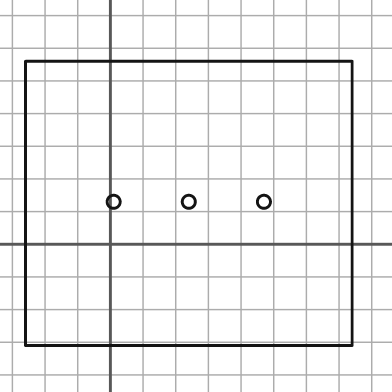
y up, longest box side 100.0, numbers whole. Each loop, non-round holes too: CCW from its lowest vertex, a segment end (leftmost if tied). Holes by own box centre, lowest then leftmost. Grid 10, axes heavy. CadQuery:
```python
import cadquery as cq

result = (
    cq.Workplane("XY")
    .moveTo(-26.0, -31.0)
    .lineTo(74.0, -31.0)
    .lineTo(74.0, 56.0)
    .lineTo(-26.0, 56.0)
    .close()
    .moveTo(1.0, 13.0)
    .circle(2.0)
    .moveTo(24.0, 13.0)
    .circle(2.0)
    .moveTo(47.0, 13.0)
    .circle(2.0)
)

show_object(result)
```